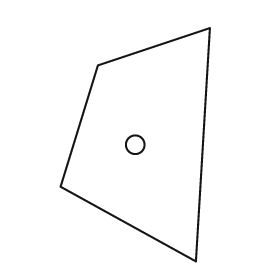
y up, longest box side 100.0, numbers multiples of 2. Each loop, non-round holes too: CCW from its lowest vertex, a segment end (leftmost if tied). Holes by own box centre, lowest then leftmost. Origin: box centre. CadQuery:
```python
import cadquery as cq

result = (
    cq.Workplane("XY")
    .moveTo(26.0, -50.0)
    .lineTo(32.0, 50.0)
    .lineTo(-16.0, 34.0)
    .lineTo(-32.0, -18.0)
    .close()
    .moveTo(0.0, 0.0)
    .circle(4.0)
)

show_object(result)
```